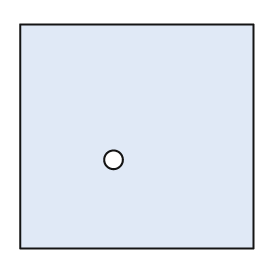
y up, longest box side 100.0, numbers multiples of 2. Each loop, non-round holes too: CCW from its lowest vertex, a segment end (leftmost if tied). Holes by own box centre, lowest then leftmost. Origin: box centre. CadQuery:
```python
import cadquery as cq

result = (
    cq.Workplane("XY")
    .moveTo(-50.0, -48.0)
    .lineTo(50.0, -48.0)
    .lineTo(50.0, 48.0)
    .lineTo(-50.0, 48.0)
    .close()
    .moveTo(-10.0, -10.0)
    .circle(4.0)
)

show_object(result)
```